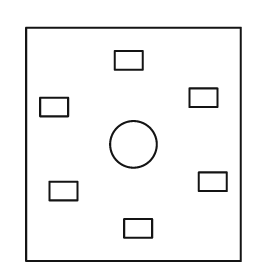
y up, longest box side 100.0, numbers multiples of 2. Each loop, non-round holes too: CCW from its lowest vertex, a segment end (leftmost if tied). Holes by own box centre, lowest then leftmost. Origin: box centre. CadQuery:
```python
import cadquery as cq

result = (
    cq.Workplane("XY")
    .moveTo(-46.0, -50.0)
    .lineTo(46.0, -50.0)
    .lineTo(46.0, 50.0)
    .lineTo(-46.0, 50.0)
    .close()
    .moveTo(-4.0, -40.0)
    .lineTo(8.0, -40.0)
    .lineTo(8.0, -32.0)
    .lineTo(-4.0, -32.0)
    .close()
    .moveTo(-36.0, -24.0)
    .lineTo(-24.0, -24.0)
    .lineTo(-24.0, -16.0)
    .lineTo(-36.0, -16.0)
    .close()
    .moveTo(28.0, -20.0)
    .lineTo(40.0, -20.0)
    .lineTo(40.0, -12.0)
    .lineTo(28.0, -12.0)
    .close()
    .moveTo(0.0, 0.0)
    .circle(10.0)
    .moveTo(-40.0, 12.0)
    .lineTo(-28.0, 12.0)
    .lineTo(-28.0, 20.0)
    .lineTo(-40.0, 20.0)
    .close()
    .moveTo(24.0, 16.0)
    .lineTo(36.0, 16.0)
    .lineTo(36.0, 24.0)
    .lineTo(24.0, 24.0)
    .close()
    .moveTo(-8.0, 32.0)
    .lineTo(4.0, 32.0)
    .lineTo(4.0, 40.0)
    .lineTo(-8.0, 40.0)
    .close()
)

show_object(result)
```